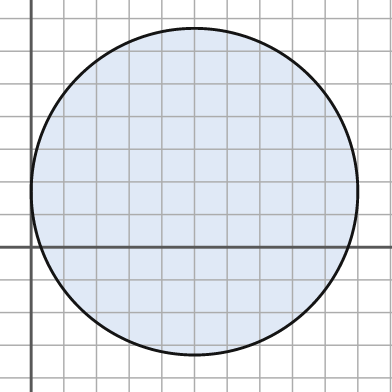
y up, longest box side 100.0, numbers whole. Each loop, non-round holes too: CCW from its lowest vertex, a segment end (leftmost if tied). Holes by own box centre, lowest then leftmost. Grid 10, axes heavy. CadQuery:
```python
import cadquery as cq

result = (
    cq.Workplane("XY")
    .moveTo(50.0, 17.0)
    .circle(50.0)
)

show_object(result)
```